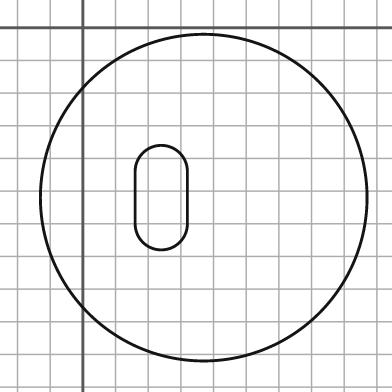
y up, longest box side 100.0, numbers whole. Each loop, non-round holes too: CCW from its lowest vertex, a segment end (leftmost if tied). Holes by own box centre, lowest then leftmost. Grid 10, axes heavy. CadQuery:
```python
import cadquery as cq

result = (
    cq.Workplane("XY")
    .moveTo(37.0, -52.0)
    .circle(50.0)
    .moveTo(16.0, -60.0)
    .threePointArc((24.0, -68.0), (32.0, -60.0))
    .lineTo(32.0, -44.0)
    .threePointArc((24.0, -36.0), (16.0, -44.0))
    .close()
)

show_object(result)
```